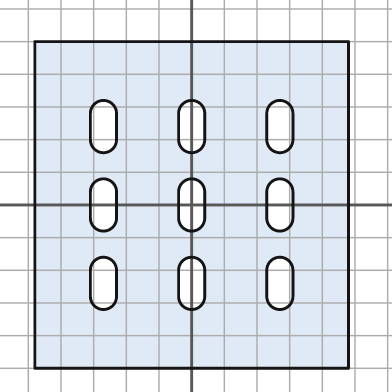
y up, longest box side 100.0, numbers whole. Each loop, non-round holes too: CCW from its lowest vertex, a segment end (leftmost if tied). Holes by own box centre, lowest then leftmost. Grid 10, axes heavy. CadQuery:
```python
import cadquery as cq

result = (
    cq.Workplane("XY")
    .moveTo(-48.0, -50.0)
    .lineTo(48.0, -50.0)
    .lineTo(48.0, 50.0)
    .lineTo(-48.0, 50.0)
    .close()
    .moveTo(-31.0, -28.0)
    .threePointArc((-27.0, -32.0), (-23.0, -28.0))
    .lineTo(-23.0, -20.0)
    .threePointArc((-27.0, -16.0), (-31.0, -20.0))
    .close()
    .moveTo(-4.0, -28.0)
    .threePointArc((0.0, -32.0), (4.0, -28.0))
    .lineTo(4.0, -20.0)
    .threePointArc((0.0, -16.0), (-4.0, -20.0))
    .close()
    .moveTo(23.0, -28.0)
    .threePointArc((27.0, -32.0), (31.0, -28.0))
    .lineTo(31.0, -20.0)
    .threePointArc((27.0, -16.0), (23.0, -20.0))
    .close()
    .moveTo(-31.0, -4.0)
    .threePointArc((-27.0, -8.0), (-23.0, -4.0))
    .lineTo(-23.0, 4.0)
    .threePointArc((-27.0, 8.0), (-31.0, 4.0))
    .close()
    .moveTo(-4.0, -4.0)
    .threePointArc((0.0, -8.0), (4.0, -4.0))
    .lineTo(4.0, 4.0)
    .threePointArc((0.0, 8.0), (-4.0, 4.0))
    .close()
    .moveTo(23.0, -4.0)
    .threePointArc((27.0, -8.0), (31.0, -4.0))
    .lineTo(31.0, 4.0)
    .threePointArc((27.0, 8.0), (23.0, 4.0))
    .close()
    .moveTo(-31.0, 20.0)
    .threePointArc((-27.0, 16.0), (-23.0, 20.0))
    .lineTo(-23.0, 28.0)
    .threePointArc((-27.0, 32.0), (-31.0, 28.0))
    .close()
    .moveTo(-4.0, 20.0)
    .threePointArc((0.0, 16.0), (4.0, 20.0))
    .lineTo(4.0, 28.0)
    .threePointArc((0.0, 32.0), (-4.0, 28.0))
    .close()
    .moveTo(23.0, 20.0)
    .threePointArc((27.0, 16.0), (31.0, 20.0))
    .lineTo(31.0, 28.0)
    .threePointArc((27.0, 32.0), (23.0, 28.0))
    .close()
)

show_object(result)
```